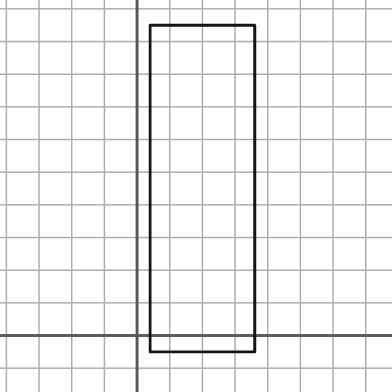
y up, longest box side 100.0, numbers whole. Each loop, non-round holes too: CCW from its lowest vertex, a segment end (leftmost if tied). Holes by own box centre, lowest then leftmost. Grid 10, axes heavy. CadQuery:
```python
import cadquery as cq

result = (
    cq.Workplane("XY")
    .moveTo(4.0, -5.0)
    .lineTo(36.0, -5.0)
    .lineTo(36.0, 95.0)
    .lineTo(4.0, 95.0)
    .close()
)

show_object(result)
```